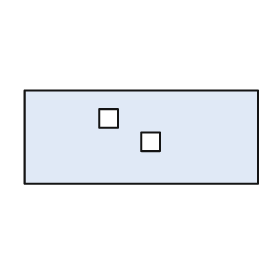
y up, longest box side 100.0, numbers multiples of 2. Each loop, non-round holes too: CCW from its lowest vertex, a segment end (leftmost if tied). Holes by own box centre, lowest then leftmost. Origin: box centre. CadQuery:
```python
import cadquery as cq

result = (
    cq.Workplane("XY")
    .moveTo(-50.0, -20.0)
    .lineTo(50.0, -20.0)
    .lineTo(50.0, 20.0)
    .lineTo(-50.0, 20.0)
    .close()
    .moveTo(0.0, -6.0)
    .lineTo(8.0, -6.0)
    .lineTo(8.0, 2.0)
    .lineTo(0.0, 2.0)
    .close()
    .moveTo(-18.0, 4.0)
    .lineTo(-10.0, 4.0)
    .lineTo(-10.0, 12.0)
    .lineTo(-18.0, 12.0)
    .close()
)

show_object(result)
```